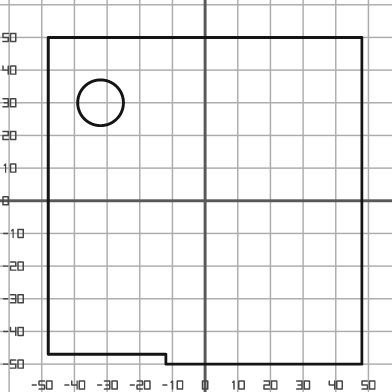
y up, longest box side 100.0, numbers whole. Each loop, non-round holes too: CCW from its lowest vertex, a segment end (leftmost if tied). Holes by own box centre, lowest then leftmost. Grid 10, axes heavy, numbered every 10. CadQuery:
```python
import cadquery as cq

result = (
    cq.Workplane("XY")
    .moveTo(-12.0, -50.0)
    .lineTo(48.0, -50.0)
    .lineTo(48.0, 50.0)
    .lineTo(-48.0, 50.0)
    .lineTo(-48.0, -47.0)
    .lineTo(-12.0, -47.0)
    .close()
    .moveTo(-32.0, 30.0)
    .circle(7.0)
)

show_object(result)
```